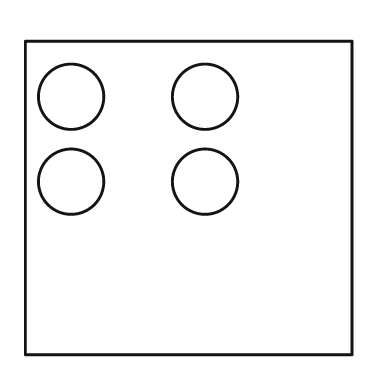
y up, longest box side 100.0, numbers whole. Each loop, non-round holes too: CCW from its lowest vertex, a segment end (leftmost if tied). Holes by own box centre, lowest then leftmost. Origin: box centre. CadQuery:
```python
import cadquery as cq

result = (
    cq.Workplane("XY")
    .moveTo(-50.0, -48.0)
    .lineTo(50.0, -48.0)
    .lineTo(50.0, 48.0)
    .lineTo(-50.0, 48.0)
    .close()
    .moveTo(-36.0, 5.0)
    .circle(10.0)
    .moveTo(5.0, 5.0)
    .circle(10.0)
    .moveTo(-36.0, 31.0)
    .circle(10.0)
    .moveTo(5.0, 31.0)
    .circle(10.0)
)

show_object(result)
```